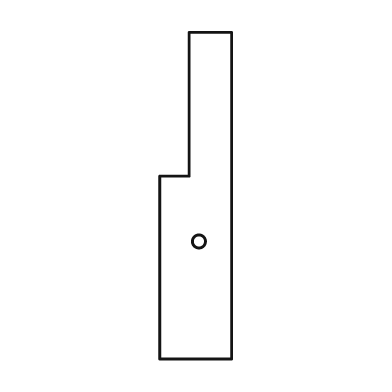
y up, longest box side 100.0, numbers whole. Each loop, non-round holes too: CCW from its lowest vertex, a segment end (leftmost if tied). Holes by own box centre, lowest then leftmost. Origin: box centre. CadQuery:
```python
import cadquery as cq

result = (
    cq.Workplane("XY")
    .moveTo(-11.0, -50.0)
    .lineTo(11.0, -50.0)
    .lineTo(11.0, 50.0)
    .lineTo(-2.0, 50.0)
    .lineTo(-2.0, 6.0)
    .lineTo(-11.0, 6.0)
    .close()
    .moveTo(1.0, -14.0)
    .circle(2.0)
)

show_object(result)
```